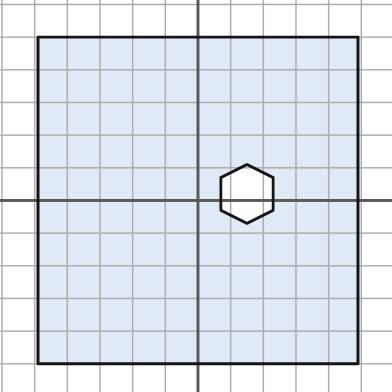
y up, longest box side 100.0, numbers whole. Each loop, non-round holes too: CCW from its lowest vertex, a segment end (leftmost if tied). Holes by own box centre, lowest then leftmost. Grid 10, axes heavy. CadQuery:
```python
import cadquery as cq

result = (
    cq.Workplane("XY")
    .moveTo(-49.0, -50.0)
    .lineTo(49.0, -50.0)
    .lineTo(49.0, 50.0)
    .lineTo(-49.0, 50.0)
    .close()
    .moveTo(15.0, -7.0)
    .lineTo(23.0, -3.0)
    .lineTo(23.0, 7.0)
    .lineTo(15.0, 11.0)
    .lineTo(7.0, 7.0)
    .lineTo(7.0, -3.0)
    .close()
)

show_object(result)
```